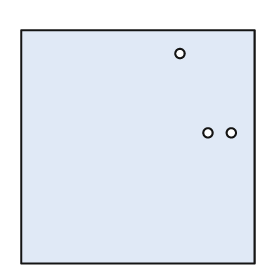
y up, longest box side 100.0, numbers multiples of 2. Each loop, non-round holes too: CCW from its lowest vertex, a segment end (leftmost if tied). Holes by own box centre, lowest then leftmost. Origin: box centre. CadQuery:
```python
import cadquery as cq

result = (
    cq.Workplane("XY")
    .moveTo(-50.0, -50.0)
    .lineTo(50.0, -50.0)
    .lineTo(50.0, 50.0)
    .lineTo(-50.0, 50.0)
    .close()
    .moveTo(30.0, 6.0)
    .circle(2.0)
    .moveTo(40.0, 6.0)
    .circle(2.0)
    .moveTo(18.0, 40.0)
    .circle(2.0)
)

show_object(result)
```